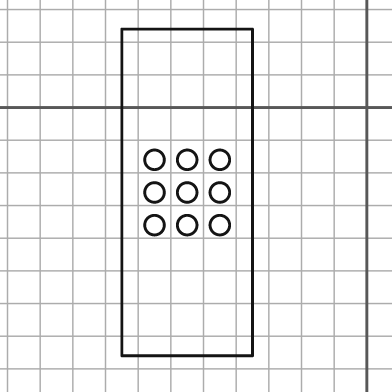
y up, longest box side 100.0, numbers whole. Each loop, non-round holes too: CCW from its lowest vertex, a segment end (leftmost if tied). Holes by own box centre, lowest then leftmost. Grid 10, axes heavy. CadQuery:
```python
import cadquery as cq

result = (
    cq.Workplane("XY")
    .moveTo(-75.0, -76.0)
    .lineTo(-35.0, -76.0)
    .lineTo(-35.0, 24.0)
    .lineTo(-75.0, 24.0)
    .close()
    .moveTo(-65.0, -36.0)
    .circle(3.0)
    .moveTo(-55.0, -36.0)
    .circle(3.0)
    .moveTo(-45.0, -36.0)
    .circle(3.0)
    .moveTo(-65.0, -26.0)
    .circle(3.0)
    .moveTo(-55.0, -26.0)
    .circle(3.0)
    .moveTo(-45.0, -26.0)
    .circle(3.0)
    .moveTo(-65.0, -16.0)
    .circle(3.0)
    .moveTo(-55.0, -16.0)
    .circle(3.0)
    .moveTo(-45.0, -16.0)
    .circle(3.0)
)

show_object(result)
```